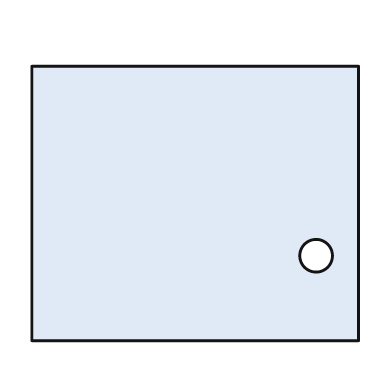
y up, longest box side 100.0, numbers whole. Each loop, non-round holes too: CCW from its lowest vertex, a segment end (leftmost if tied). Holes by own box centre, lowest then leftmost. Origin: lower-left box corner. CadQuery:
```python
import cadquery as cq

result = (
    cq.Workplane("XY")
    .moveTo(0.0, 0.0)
    .lineTo(100.0, 0.0)
    .lineTo(100.0, 84.0)
    .lineTo(0.0, 84.0)
    .close()
    .moveTo(87.0, 26.0)
    .circle(5.0)
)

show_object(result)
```